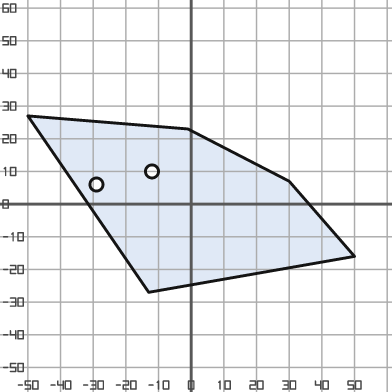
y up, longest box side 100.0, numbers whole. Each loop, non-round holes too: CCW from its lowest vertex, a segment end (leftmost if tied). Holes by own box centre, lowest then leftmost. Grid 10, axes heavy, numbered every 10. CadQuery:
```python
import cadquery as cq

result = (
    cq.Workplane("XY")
    .moveTo(-13.0, -27.0)
    .lineTo(50.0, -16.0)
    .lineTo(30.0, 7.0)
    .lineTo(-1.0, 23.0)
    .lineTo(-50.0, 27.0)
    .close()
    .moveTo(-29.0, 6.0)
    .circle(2.0)
    .moveTo(-12.0, 10.0)
    .circle(2.0)
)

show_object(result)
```